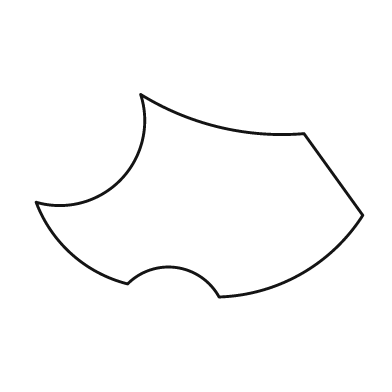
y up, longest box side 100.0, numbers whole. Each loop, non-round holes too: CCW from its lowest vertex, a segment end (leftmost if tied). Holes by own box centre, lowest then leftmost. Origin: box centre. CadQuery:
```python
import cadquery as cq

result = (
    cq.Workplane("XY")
    .moveTo(6.0, -31.0)
    .threePointArc((31.0, -24.0), (50.0, -6.0))
    .lineTo(32.0, 19.0)
    .threePointArc((6.0, 21.0), (-18.0, 31.0))
    .threePointArc((-24.0, 5.0), (-50.0, -2.0))
    .threePointArc((-39.0, -18.0), (-22.0, -27.0))
    .threePointArc((-7.0, -22.0), (6.0, -31.0))
    .close()
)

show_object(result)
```